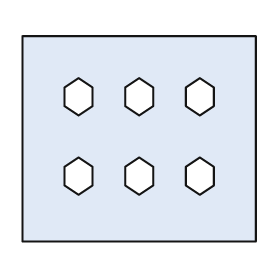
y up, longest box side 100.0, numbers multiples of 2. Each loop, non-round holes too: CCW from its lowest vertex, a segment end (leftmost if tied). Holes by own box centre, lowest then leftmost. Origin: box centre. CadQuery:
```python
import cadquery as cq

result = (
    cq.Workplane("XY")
    .moveTo(-50.0, -44.0)
    .lineTo(50.0, -44.0)
    .lineTo(50.0, 44.0)
    .lineTo(-50.0, 44.0)
    .close()
    .moveTo(-26.0, -24.0)
    .lineTo(-20.0, -20.0)
    .lineTo(-20.0, -12.0)
    .lineTo(-26.0, -8.0)
    .lineTo(-32.0, -12.0)
    .lineTo(-32.0, -20.0)
    .close()
    .moveTo(0.0, -24.0)
    .lineTo(6.0, -20.0)
    .lineTo(6.0, -12.0)
    .lineTo(0.0, -8.0)
    .lineTo(-6.0, -12.0)
    .lineTo(-6.0, -20.0)
    .close()
    .moveTo(26.0, -24.0)
    .lineTo(32.0, -20.0)
    .lineTo(32.0, -12.0)
    .lineTo(26.0, -8.0)
    .lineTo(20.0, -12.0)
    .lineTo(20.0, -20.0)
    .close()
    .moveTo(-26.0, 10.0)
    .lineTo(-20.0, 14.0)
    .lineTo(-20.0, 22.0)
    .lineTo(-26.0, 26.0)
    .lineTo(-32.0, 22.0)
    .lineTo(-32.0, 14.0)
    .close()
    .moveTo(0.0, 10.0)
    .lineTo(6.0, 14.0)
    .lineTo(6.0, 22.0)
    .lineTo(0.0, 26.0)
    .lineTo(-6.0, 22.0)
    .lineTo(-6.0, 14.0)
    .close()
    .moveTo(26.0, 10.0)
    .lineTo(32.0, 14.0)
    .lineTo(32.0, 22.0)
    .lineTo(26.0, 26.0)
    .lineTo(20.0, 22.0)
    .lineTo(20.0, 14.0)
    .close()
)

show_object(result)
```